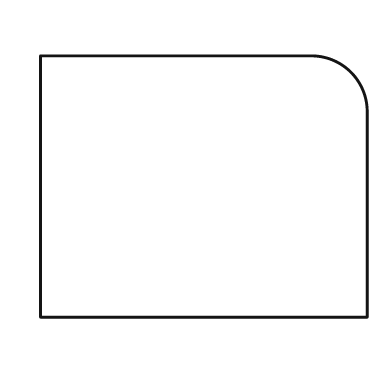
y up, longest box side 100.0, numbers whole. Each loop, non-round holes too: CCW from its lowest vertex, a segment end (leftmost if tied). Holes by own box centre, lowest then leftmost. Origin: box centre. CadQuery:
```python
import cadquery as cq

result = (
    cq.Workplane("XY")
    .moveTo(-50.0, -40.0)
    .lineTo(50.0, -40.0)
    .lineTo(50.0, 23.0)
    .threePointArc((45.0, 35.0), (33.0, 40.0))
    .lineTo(-50.0, 40.0)
    .close()
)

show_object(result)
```